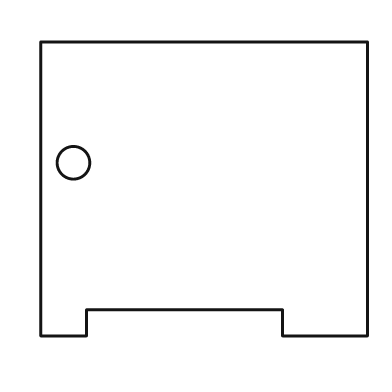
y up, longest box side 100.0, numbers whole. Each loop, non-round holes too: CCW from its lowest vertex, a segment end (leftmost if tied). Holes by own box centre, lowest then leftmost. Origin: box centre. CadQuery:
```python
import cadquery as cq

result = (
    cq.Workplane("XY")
    .moveTo(-50.0, -45.0)
    .lineTo(-36.0, -45.0)
    .lineTo(-36.0, -37.0)
    .lineTo(24.0, -37.0)
    .lineTo(24.0, -45.0)
    .lineTo(50.0, -45.0)
    .lineTo(50.0, 45.0)
    .lineTo(-50.0, 45.0)
    .close()
    .moveTo(-40.0, 8.0)
    .circle(5.0)
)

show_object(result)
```